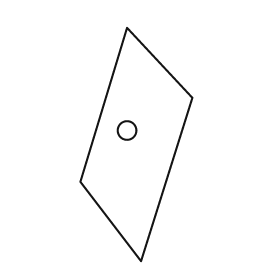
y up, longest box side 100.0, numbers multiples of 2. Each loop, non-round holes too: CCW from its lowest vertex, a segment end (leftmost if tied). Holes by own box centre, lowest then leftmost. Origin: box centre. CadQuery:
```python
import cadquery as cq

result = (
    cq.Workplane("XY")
    .moveTo(2.0, -50.0)
    .lineTo(24.0, 20.0)
    .lineTo(-4.0, 50.0)
    .lineTo(-24.0, -16.0)
    .close()
    .moveTo(-4.0, 6.0)
    .circle(4.0)
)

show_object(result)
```